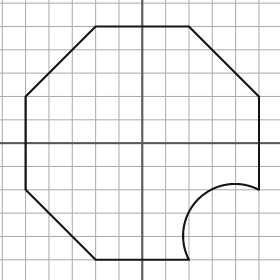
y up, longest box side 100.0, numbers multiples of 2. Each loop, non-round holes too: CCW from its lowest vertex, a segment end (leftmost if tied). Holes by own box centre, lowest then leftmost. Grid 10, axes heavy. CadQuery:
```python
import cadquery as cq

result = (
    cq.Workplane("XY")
    .moveTo(-20.0, -50.0)
    .lineTo(20.0, -50.0)
    .threePointArc((24.0, -24.0), (50.0, -20.0))
    .lineTo(50.0, 20.0)
    .lineTo(20.0, 50.0)
    .lineTo(-20.0, 50.0)
    .lineTo(-50.0, 20.0)
    .lineTo(-50.0, -20.0)
    .close()
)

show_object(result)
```